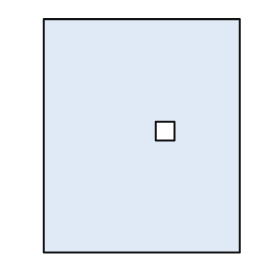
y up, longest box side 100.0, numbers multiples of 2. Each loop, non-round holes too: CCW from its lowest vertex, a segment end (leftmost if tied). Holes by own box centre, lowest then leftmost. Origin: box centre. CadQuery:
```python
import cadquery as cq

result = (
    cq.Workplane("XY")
    .moveTo(-42.0, -50.0)
    .lineTo(42.0, -50.0)
    .lineTo(42.0, 50.0)
    .lineTo(-42.0, 50.0)
    .close()
    .moveTo(6.0, -2.0)
    .lineTo(14.0, -2.0)
    .lineTo(14.0, 6.0)
    .lineTo(6.0, 6.0)
    .close()
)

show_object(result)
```